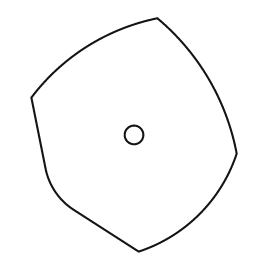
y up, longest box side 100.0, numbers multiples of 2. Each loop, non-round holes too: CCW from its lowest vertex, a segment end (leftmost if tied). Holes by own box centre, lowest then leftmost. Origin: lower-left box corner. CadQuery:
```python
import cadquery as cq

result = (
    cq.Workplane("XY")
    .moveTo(46.0, 0.0)
    .threePointArc((72.0, 16.0), (88.0, 42.0))
    .threePointArc((76.0, 74.0), (54.0, 100.0))
    .threePointArc((24.0, 88.0), (0.0, 66.0))
    .lineTo(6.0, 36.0)
    .threePointArc((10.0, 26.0), (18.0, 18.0))
    .close()
    .moveTo(44.0, 50.0)
    .circle(4.0)
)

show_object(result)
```